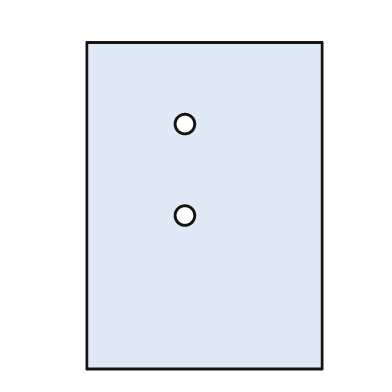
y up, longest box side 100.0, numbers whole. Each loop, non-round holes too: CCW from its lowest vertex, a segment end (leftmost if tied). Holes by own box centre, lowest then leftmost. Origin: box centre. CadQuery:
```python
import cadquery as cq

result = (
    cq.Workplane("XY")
    .moveTo(-36.0, -50.0)
    .lineTo(36.0, -50.0)
    .lineTo(36.0, 50.0)
    .lineTo(-36.0, 50.0)
    .close()
    .moveTo(-6.0, -3.0)
    .circle(3.0)
    .moveTo(-6.0, 25.0)
    .circle(3.0)
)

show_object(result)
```